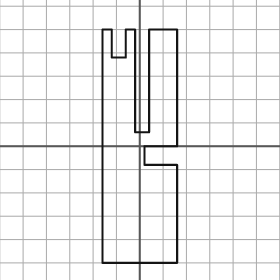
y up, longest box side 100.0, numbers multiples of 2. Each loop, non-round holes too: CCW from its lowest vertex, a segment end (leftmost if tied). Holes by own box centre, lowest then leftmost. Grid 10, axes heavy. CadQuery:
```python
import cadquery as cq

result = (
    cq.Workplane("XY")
    .moveTo(-16.0, -50.0)
    .lineTo(16.0, -50.0)
    .lineTo(16.0, -8.0)
    .lineTo(2.0, -8.0)
    .lineTo(2.0, 0.0)
    .lineTo(16.0, 0.0)
    .lineTo(16.0, 50.0)
    .lineTo(4.0, 50.0)
    .lineTo(4.0, 6.0)
    .lineTo(-2.0, 6.0)
    .lineTo(-2.0, 50.0)
    .lineTo(-6.0, 50.0)
    .lineTo(-6.0, 38.0)
    .lineTo(-12.0, 38.0)
    .lineTo(-12.0, 50.0)
    .lineTo(-16.0, 50.0)
    .close()
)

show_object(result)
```